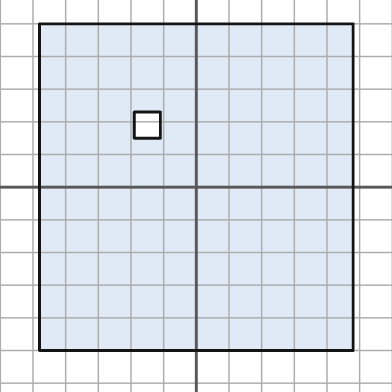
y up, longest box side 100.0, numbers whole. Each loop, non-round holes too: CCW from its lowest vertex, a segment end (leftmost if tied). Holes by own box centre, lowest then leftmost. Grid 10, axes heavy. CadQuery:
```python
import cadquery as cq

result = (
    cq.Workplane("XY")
    .moveTo(-48.0, -50.0)
    .lineTo(48.0, -50.0)
    .lineTo(48.0, 50.0)
    .lineTo(-48.0, 50.0)
    .close()
    .moveTo(-19.0, 15.0)
    .lineTo(-11.0, 15.0)
    .lineTo(-11.0, 23.0)
    .lineTo(-19.0, 23.0)
    .close()
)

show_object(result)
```